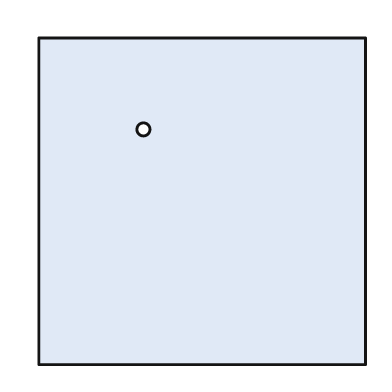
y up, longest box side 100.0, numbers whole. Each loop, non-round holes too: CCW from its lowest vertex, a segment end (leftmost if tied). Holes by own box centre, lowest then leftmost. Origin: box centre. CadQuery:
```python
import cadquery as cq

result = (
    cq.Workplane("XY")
    .moveTo(-50.0, -50.0)
    .lineTo(50.0, -50.0)
    .lineTo(50.0, 50.0)
    .lineTo(-50.0, 50.0)
    .close()
    .moveTo(-18.0, 22.0)
    .circle(2.0)
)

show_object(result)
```